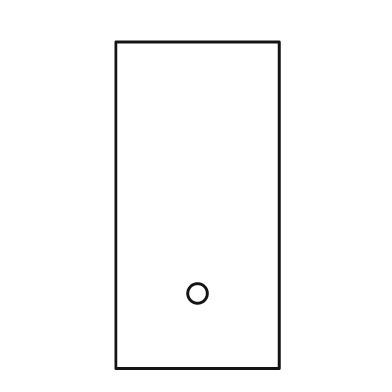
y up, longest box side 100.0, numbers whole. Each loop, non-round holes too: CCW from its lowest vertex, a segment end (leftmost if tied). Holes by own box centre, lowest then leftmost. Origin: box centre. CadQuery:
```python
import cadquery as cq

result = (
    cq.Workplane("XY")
    .moveTo(-25.0, -50.0)
    .lineTo(25.0, -50.0)
    .lineTo(25.0, 50.0)
    .lineTo(-25.0, 50.0)
    .close()
    .moveTo(0.0, -27.0)
    .circle(3.0)
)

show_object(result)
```